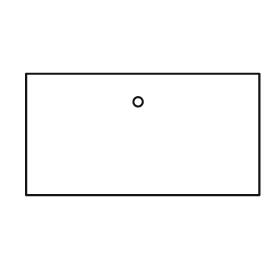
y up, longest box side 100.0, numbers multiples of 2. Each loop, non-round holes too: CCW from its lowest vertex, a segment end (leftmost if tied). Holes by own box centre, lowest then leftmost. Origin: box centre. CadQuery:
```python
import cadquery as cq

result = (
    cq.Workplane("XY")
    .moveTo(-50.0, -26.0)
    .lineTo(50.0, -26.0)
    .lineTo(50.0, 26.0)
    .lineTo(-50.0, 26.0)
    .close()
    .moveTo(-2.0, 14.0)
    .circle(2.0)
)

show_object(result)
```